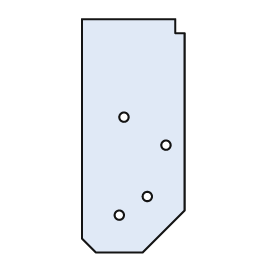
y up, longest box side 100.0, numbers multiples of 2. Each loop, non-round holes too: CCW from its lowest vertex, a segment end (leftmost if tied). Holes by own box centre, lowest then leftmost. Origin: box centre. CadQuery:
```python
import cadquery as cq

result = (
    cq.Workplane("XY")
    .moveTo(-16.0, -50.0)
    .lineTo(4.0, -50.0)
    .lineTo(22.0, -32.0)
    .lineTo(22.0, 44.0)
    .lineTo(18.0, 44.0)
    .lineTo(18.0, 50.0)
    .lineTo(-22.0, 50.0)
    .lineTo(-22.0, -44.0)
    .close()
    .moveTo(-6.0, -34.0)
    .circle(2.0)
    .moveTo(6.0, -26.0)
    .circle(2.0)
    .moveTo(14.0, -4.0)
    .circle(2.0)
    .moveTo(-4.0, 8.0)
    .circle(2.0)
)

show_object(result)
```